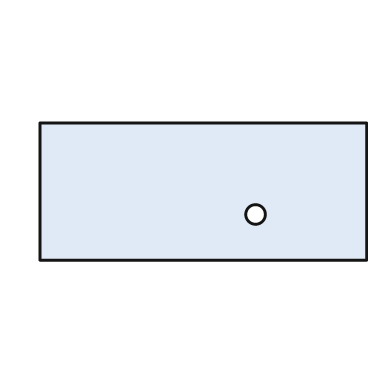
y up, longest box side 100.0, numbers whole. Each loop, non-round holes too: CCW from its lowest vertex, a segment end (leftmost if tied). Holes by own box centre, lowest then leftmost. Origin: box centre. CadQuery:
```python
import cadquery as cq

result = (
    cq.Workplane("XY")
    .moveTo(-50.0, -21.0)
    .lineTo(50.0, -21.0)
    .lineTo(50.0, 21.0)
    .lineTo(-50.0, 21.0)
    .close()
    .moveTo(16.0, -7.0)
    .circle(3.0)
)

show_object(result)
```